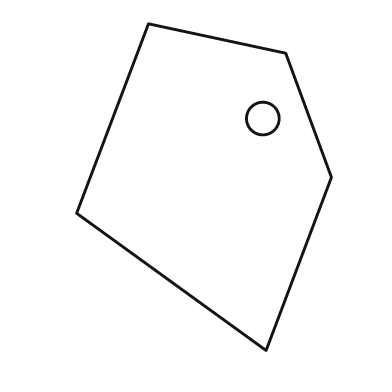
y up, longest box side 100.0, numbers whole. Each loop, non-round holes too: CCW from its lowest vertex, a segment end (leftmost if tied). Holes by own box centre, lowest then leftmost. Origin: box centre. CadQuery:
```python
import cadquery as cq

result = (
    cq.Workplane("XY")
    .moveTo(19.0, -50.0)
    .lineTo(39.0, 3.0)
    .lineTo(25.0, 41.0)
    .lineTo(-17.0, 50.0)
    .lineTo(-39.0, -8.0)
    .close()
    .moveTo(18.0, 21.0)
    .circle(5.0)
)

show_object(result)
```